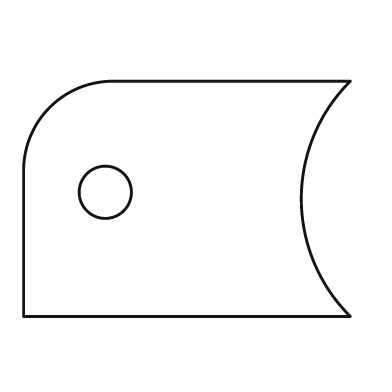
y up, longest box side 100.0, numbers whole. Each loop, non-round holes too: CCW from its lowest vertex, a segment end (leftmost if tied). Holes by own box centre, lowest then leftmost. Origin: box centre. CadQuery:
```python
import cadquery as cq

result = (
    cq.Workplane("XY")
    .moveTo(-50.0, -36.0)
    .lineTo(50.0, -36.0)
    .threePointArc((35.0, 0.0), (50.0, 36.0))
    .lineTo(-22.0, 36.0)
    .threePointArc((-42.0, 28.0), (-50.0, 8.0))
    .close()
    .moveTo(-25.0, 2.0)
    .circle(8.0)
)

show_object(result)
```